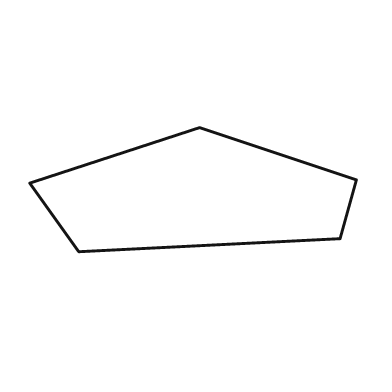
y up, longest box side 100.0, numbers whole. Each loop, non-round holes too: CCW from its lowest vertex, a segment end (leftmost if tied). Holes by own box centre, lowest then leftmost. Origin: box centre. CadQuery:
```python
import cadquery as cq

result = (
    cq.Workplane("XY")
    .moveTo(-35.0, -19.0)
    .lineTo(45.0, -15.0)
    .lineTo(50.0, 3.0)
    .lineTo(2.0, 19.0)
    .lineTo(-50.0, 2.0)
    .close()
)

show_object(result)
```